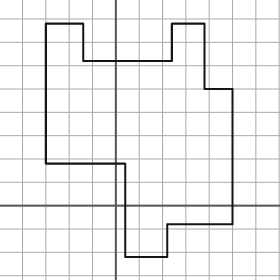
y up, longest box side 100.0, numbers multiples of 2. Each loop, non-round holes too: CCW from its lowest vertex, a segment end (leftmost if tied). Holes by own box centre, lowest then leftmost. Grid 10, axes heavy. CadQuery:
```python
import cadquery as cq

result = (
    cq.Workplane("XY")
    .moveTo(4.0, -22.0)
    .lineTo(22.0, -22.0)
    .lineTo(22.0, -8.0)
    .lineTo(50.0, -8.0)
    .lineTo(50.0, 50.0)
    .lineTo(38.0, 50.0)
    .lineTo(38.0, 78.0)
    .lineTo(24.0, 78.0)
    .lineTo(24.0, 62.0)
    .lineTo(-14.0, 62.0)
    .lineTo(-14.0, 78.0)
    .lineTo(-30.0, 78.0)
    .lineTo(-30.0, 18.0)
    .lineTo(4.0, 18.0)
    .close()
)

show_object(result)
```